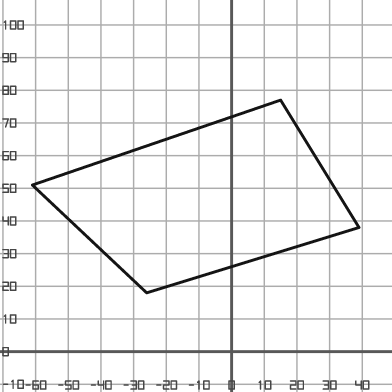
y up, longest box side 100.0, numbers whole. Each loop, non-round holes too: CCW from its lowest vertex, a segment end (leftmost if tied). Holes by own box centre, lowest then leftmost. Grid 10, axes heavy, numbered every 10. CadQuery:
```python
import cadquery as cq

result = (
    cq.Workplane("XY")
    .moveTo(-26.0, 18.0)
    .lineTo(39.0, 38.0)
    .lineTo(15.0, 77.0)
    .lineTo(-61.0, 51.0)
    .close()
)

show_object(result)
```